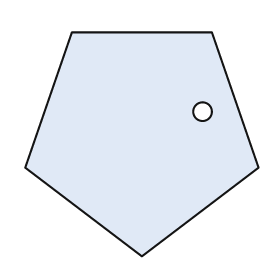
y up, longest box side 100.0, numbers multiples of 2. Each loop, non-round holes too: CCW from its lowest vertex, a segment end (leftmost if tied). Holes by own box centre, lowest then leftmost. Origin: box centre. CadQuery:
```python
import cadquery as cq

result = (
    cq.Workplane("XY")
    .moveTo(0.0, -48.0)
    .lineTo(50.0, -10.0)
    .lineTo(30.0, 48.0)
    .lineTo(-30.0, 48.0)
    .lineTo(-50.0, -10.0)
    .close()
    .moveTo(26.0, 14.0)
    .circle(4.0)
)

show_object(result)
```